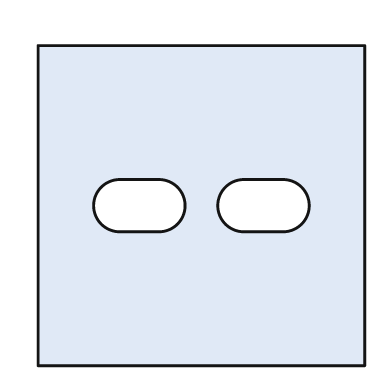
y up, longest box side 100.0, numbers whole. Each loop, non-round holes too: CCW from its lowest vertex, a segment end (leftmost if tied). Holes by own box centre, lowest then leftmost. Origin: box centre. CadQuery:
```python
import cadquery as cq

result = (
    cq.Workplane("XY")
    .moveTo(-50.0, -49.0)
    .lineTo(50.0, -49.0)
    .lineTo(50.0, 49.0)
    .lineTo(-50.0, 49.0)
    .close()
    .moveTo(-25.0, -8.0)
    .lineTo(-13.0, -8.0)
    .threePointArc((-5.0, 0.0), (-13.0, 8.0))
    .lineTo(-25.0, 8.0)
    .threePointArc((-33.0, 0.0), (-25.0, -8.0))
    .close()
    .moveTo(13.0, -8.0)
    .lineTo(25.0, -8.0)
    .threePointArc((33.0, 0.0), (25.0, 8.0))
    .lineTo(13.0, 8.0)
    .threePointArc((5.0, 0.0), (13.0, -8.0))
    .close()
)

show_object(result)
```